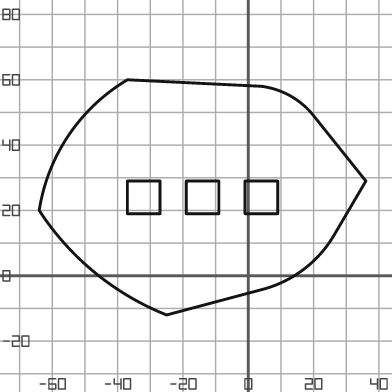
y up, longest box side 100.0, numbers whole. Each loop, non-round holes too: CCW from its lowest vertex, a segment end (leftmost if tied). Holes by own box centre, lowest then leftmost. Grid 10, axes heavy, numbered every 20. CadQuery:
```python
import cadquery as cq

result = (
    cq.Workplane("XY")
    .moveTo(-25.0, -12.0)
    .lineTo(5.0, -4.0)
    .threePointArc((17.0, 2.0), (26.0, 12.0))
    .lineTo(36.0, 29.0)
    .lineTo(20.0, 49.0)
    .threePointArc((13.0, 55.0), (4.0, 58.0))
    .lineTo(-37.0, 60.0)
    .threePointArc((-55.0, 43.0), (-64.0, 20.0))
    .threePointArc((-47.0, 1.0), (-25.0, -12.0))
    .close()
    .moveTo(-37.0, 19.0)
    .lineTo(-27.0, 19.0)
    .lineTo(-27.0, 29.0)
    .lineTo(-37.0, 29.0)
    .close()
    .moveTo(-19.0, 19.0)
    .lineTo(-9.0, 19.0)
    .lineTo(-9.0, 29.0)
    .lineTo(-19.0, 29.0)
    .close()
    .moveTo(-1.0, 19.0)
    .lineTo(9.0, 19.0)
    .lineTo(9.0, 29.0)
    .lineTo(-1.0, 29.0)
    .close()
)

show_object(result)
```